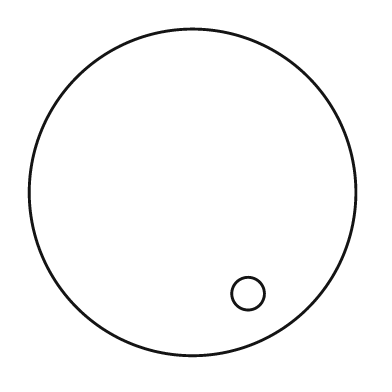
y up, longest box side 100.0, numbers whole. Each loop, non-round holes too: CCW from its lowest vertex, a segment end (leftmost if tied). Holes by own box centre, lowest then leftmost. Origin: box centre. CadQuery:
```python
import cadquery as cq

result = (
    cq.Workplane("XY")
    .moveTo(0.0, 0.0)
    .circle(50.0)
    .moveTo(17.0, -31.0)
    .circle(5.0)
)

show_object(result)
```